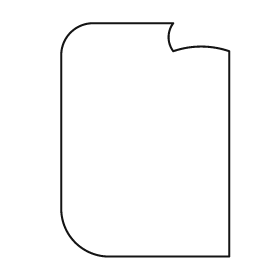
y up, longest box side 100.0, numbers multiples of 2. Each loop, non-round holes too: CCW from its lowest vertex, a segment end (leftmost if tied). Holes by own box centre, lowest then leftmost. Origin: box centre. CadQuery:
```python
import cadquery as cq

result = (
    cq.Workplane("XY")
    .moveTo(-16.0, -50.0)
    .lineTo(36.0, -50.0)
    .lineTo(36.0, 38.0)
    .threePointArc((24.0, 40.0), (12.0, 38.0))
    .threePointArc((10.0, 44.0), (12.0, 50.0))
    .lineTo(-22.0, 50.0)
    .threePointArc((-32.0, 46.0), (-36.0, 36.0))
    .lineTo(-36.0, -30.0)
    .threePointArc((-30.0, -44.0), (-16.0, -50.0))
    .close()
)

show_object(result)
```